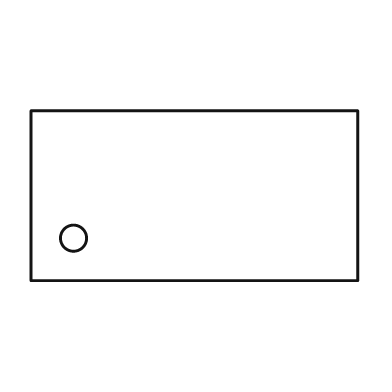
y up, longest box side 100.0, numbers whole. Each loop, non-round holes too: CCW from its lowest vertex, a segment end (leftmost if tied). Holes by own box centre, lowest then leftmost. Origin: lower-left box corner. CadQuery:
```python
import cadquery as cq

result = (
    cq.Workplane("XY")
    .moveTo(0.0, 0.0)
    .lineTo(100.0, 0.0)
    .lineTo(100.0, 52.0)
    .lineTo(0.0, 52.0)
    .close()
    .moveTo(13.0, 13.0)
    .circle(4.0)
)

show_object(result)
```